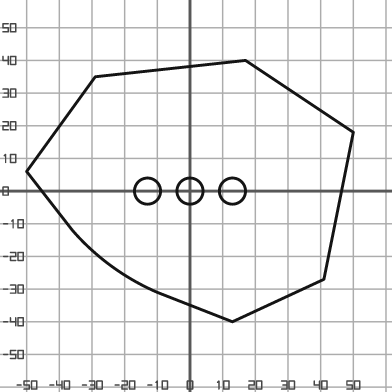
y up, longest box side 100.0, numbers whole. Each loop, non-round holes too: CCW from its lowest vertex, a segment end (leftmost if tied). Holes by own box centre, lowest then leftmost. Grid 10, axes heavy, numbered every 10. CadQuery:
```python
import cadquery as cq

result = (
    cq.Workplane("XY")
    .moveTo(13.0, -40.0)
    .lineTo(41.0, -27.0)
    .lineTo(50.0, 18.0)
    .lineTo(17.0, 40.0)
    .lineTo(-29.0, 35.0)
    .lineTo(-50.0, 6.0)
    .lineTo(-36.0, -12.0)
    .threePointArc((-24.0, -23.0), (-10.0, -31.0))
    .close()
    .moveTo(-13.0, 0.0)
    .circle(4.0)
    .moveTo(0.0, 0.0)
    .circle(4.0)
    .moveTo(13.0, 0.0)
    .circle(4.0)
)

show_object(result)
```